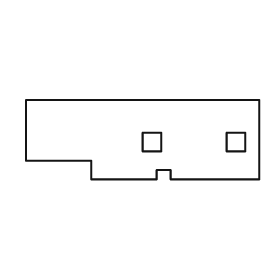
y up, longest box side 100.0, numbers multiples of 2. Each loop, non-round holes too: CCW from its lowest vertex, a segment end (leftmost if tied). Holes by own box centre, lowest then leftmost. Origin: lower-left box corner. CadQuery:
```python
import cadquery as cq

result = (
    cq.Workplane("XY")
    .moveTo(28.0, 0.0)
    .lineTo(56.0, 0.0)
    .lineTo(56.0, 4.0)
    .lineTo(62.0, 4.0)
    .lineTo(62.0, 0.0)
    .lineTo(100.0, 0.0)
    .lineTo(100.0, 34.0)
    .lineTo(0.0, 34.0)
    .lineTo(0.0, 8.0)
    .lineTo(28.0, 8.0)
    .close()
    .moveTo(50.0, 12.0)
    .lineTo(58.0, 12.0)
    .lineTo(58.0, 20.0)
    .lineTo(50.0, 20.0)
    .close()
    .moveTo(86.0, 12.0)
    .lineTo(94.0, 12.0)
    .lineTo(94.0, 20.0)
    .lineTo(86.0, 20.0)
    .close()
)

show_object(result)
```